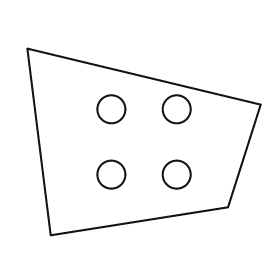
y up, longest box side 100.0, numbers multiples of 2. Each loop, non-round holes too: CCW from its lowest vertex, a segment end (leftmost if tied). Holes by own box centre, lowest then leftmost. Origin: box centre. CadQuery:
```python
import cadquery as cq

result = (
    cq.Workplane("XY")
    .moveTo(-40.0, -40.0)
    .lineTo(36.0, -28.0)
    .lineTo(50.0, 16.0)
    .lineTo(-50.0, 40.0)
    .close()
    .moveTo(-14.0, -14.0)
    .circle(6.0)
    .moveTo(14.0, -14.0)
    .circle(6.0)
    .moveTo(-14.0, 14.0)
    .circle(6.0)
    .moveTo(14.0, 14.0)
    .circle(6.0)
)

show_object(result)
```